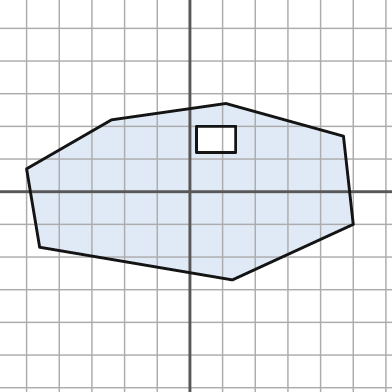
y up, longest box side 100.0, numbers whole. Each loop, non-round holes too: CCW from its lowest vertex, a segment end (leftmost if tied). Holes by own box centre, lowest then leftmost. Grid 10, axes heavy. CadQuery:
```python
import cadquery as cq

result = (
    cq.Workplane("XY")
    .moveTo(13.0, -27.0)
    .lineTo(50.0, -10.0)
    .lineTo(47.0, 17.0)
    .lineTo(11.0, 27.0)
    .lineTo(-24.0, 22.0)
    .lineTo(-50.0, 7.0)
    .lineTo(-46.0, -17.0)
    .close()
    .moveTo(2.0, 12.0)
    .lineTo(14.0, 12.0)
    .lineTo(14.0, 20.0)
    .lineTo(2.0, 20.0)
    .close()
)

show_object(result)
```